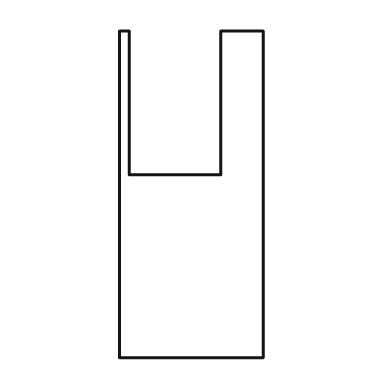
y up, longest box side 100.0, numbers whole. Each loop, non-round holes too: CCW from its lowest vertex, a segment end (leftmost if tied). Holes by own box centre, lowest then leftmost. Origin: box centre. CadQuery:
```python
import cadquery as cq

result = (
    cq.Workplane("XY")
    .moveTo(-22.0, -50.0)
    .lineTo(22.0, -50.0)
    .lineTo(22.0, 50.0)
    .lineTo(9.0, 50.0)
    .lineTo(9.0, 6.0)
    .lineTo(-19.0, 6.0)
    .lineTo(-19.0, 50.0)
    .lineTo(-22.0, 50.0)
    .close()
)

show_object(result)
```